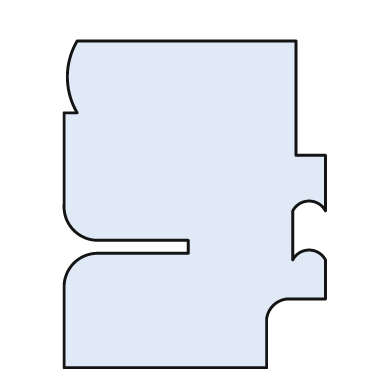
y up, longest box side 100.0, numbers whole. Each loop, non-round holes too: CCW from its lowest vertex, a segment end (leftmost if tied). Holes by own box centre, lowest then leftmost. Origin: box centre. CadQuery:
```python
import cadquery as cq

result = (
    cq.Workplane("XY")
    .moveTo(-40.0, -50.0)
    .lineTo(22.0, -50.0)
    .lineTo(22.0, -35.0)
    .threePointArc((24.0, -31.0), (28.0, -29.0))
    .lineTo(40.0, -29.0)
    .lineTo(40.0, -17.0)
    .threePointArc((35.0, -14.0), (30.0, -17.0))
    .lineTo(30.0, -2.0)
    .threePointArc((35.0, 1.0), (40.0, -2.0))
    .lineTo(40.0, 15.0)
    .lineTo(31.0, 15.0)
    .lineTo(31.0, 50.0)
    .lineTo(-36.0, 50.0)
    .threePointArc((-39.0, 39.0), (-36.0, 28.0))
    .lineTo(-40.0, 28.0)
    .lineTo(-40.0, 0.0)
    .threePointArc((-37.0, -8.0), (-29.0, -11.0))
    .lineTo(-2.0, -11.0)
    .lineTo(-2.0, -15.0)
    .lineTo(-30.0, -15.0)
    .threePointArc((-37.0, -18.0), (-40.0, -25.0))
    .close()
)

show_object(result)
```